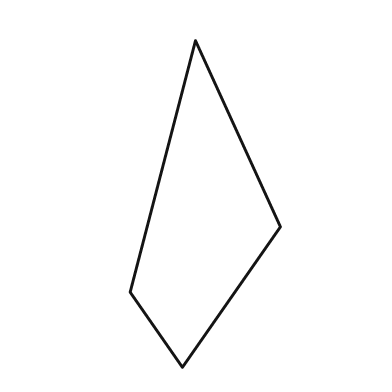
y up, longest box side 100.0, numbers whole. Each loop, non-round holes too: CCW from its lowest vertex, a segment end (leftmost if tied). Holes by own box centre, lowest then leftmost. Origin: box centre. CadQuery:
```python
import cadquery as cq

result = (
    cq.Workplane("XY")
    .moveTo(-7.0, -50.0)
    .lineTo(23.0, -7.0)
    .lineTo(-3.0, 50.0)
    .lineTo(-23.0, -27.0)
    .close()
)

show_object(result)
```